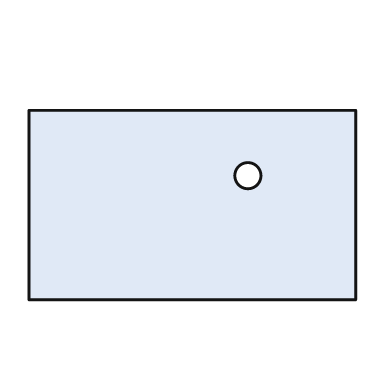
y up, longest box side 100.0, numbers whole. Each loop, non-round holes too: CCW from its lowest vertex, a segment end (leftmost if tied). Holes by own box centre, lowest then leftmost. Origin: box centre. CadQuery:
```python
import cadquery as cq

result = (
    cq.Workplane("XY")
    .moveTo(-50.0, -29.0)
    .lineTo(50.0, -29.0)
    .lineTo(50.0, 29.0)
    .lineTo(-50.0, 29.0)
    .close()
    .moveTo(17.0, 9.0)
    .circle(4.0)
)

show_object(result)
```